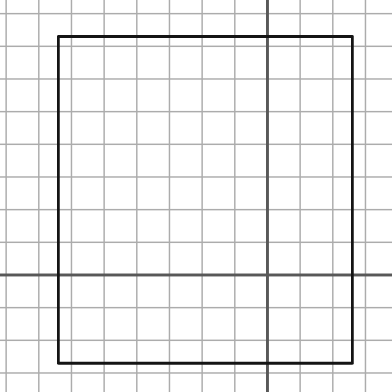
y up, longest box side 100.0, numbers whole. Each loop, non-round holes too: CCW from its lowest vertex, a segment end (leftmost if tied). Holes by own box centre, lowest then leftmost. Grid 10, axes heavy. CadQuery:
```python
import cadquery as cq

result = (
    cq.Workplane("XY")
    .moveTo(-64.0, -27.0)
    .lineTo(26.0, -27.0)
    .lineTo(26.0, 73.0)
    .lineTo(-64.0, 73.0)
    .close()
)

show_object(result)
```